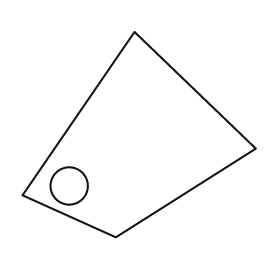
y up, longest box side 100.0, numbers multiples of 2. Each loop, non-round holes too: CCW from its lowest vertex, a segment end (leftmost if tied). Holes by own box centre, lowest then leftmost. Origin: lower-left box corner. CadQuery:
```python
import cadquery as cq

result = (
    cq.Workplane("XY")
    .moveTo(40.0, 0.0)
    .lineTo(100.0, 38.0)
    .lineTo(48.0, 88.0)
    .lineTo(0.0, 18.0)
    .close()
    .moveTo(20.0, 22.0)
    .circle(8.0)
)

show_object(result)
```